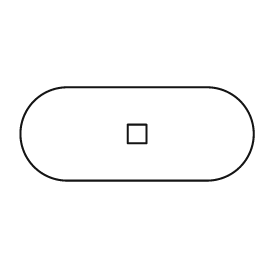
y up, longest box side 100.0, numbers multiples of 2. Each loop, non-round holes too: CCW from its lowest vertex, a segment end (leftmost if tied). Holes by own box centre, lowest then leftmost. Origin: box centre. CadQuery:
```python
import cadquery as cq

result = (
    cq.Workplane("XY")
    .moveTo(-30.0, -20.0)
    .lineTo(30.0, -20.0)
    .threePointArc((50.0, 0.0), (30.0, 20.0))
    .lineTo(-30.0, 20.0)
    .threePointArc((-50.0, 0.0), (-30.0, -20.0))
    .close()
    .moveTo(-4.0, -4.0)
    .lineTo(4.0, -4.0)
    .lineTo(4.0, 4.0)
    .lineTo(-4.0, 4.0)
    .close()
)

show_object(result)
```